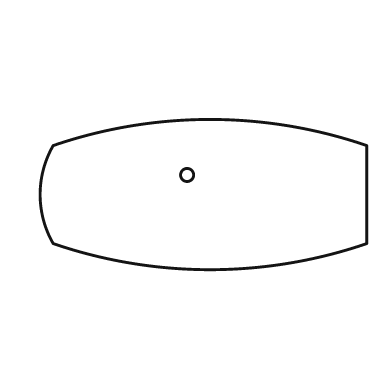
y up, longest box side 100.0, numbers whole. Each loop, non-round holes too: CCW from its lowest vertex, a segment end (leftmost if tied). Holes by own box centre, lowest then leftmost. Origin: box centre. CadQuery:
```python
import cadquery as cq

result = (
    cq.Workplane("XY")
    .moveTo(-46.0, -15.0)
    .threePointArc((2.0, -23.0), (50.0, -15.0))
    .lineTo(50.0, 15.0)
    .threePointArc((2.0, 23.0), (-46.0, 15.0))
    .threePointArc((-50.0, 0.0), (-46.0, -15.0))
    .close()
    .moveTo(-5.0, 6.0)
    .circle(2.0)
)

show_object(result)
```